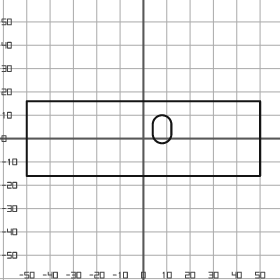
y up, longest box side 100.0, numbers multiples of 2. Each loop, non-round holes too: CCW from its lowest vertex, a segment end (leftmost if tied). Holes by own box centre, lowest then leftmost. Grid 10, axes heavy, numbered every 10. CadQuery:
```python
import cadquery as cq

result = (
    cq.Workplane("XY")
    .moveTo(-50.0, -16.0)
    .lineTo(50.0, -16.0)
    .lineTo(50.0, 16.0)
    .lineTo(-50.0, 16.0)
    .close()
    .moveTo(4.0, 2.0)
    .threePointArc((8.0, -2.0), (12.0, 2.0))
    .lineTo(12.0, 6.0)
    .threePointArc((8.0, 10.0), (4.0, 6.0))
    .close()
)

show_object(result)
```